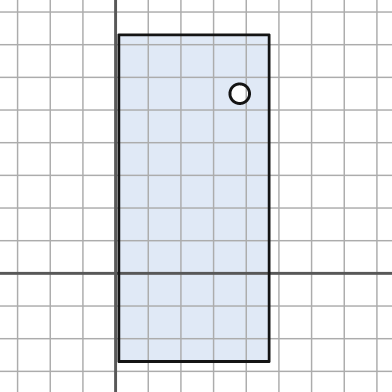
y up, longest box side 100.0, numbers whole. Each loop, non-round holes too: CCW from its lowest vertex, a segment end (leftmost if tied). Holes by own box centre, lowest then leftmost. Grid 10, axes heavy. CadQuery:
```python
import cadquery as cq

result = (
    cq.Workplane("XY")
    .moveTo(1.0, -27.0)
    .lineTo(47.0, -27.0)
    .lineTo(47.0, 73.0)
    .lineTo(1.0, 73.0)
    .close()
    .moveTo(38.0, 55.0)
    .circle(3.0)
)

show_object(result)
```